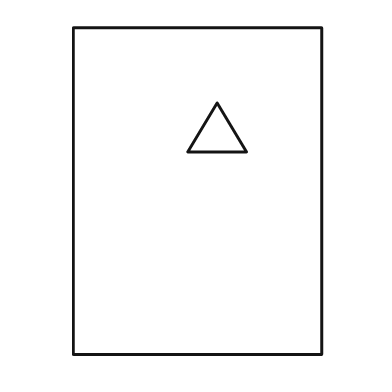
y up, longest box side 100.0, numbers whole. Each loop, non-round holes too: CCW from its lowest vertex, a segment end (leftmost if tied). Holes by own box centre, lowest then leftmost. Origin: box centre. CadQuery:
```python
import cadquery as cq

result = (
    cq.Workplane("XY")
    .moveTo(-38.0, -50.0)
    .lineTo(38.0, -50.0)
    .lineTo(38.0, 50.0)
    .lineTo(-38.0, 50.0)
    .close()
    .moveTo(-3.0, 12.0)
    .lineTo(15.0, 12.0)
    .lineTo(6.0, 27.0)
    .close()
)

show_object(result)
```